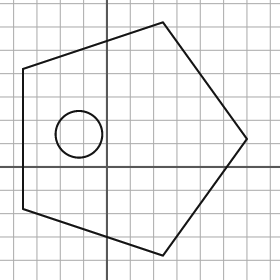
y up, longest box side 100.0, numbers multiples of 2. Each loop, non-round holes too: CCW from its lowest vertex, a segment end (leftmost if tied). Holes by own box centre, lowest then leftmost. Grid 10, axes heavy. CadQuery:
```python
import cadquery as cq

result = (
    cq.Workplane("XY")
    .moveTo(24.0, -38.0)
    .lineTo(60.0, 12.0)
    .lineTo(24.0, 62.0)
    .lineTo(-36.0, 42.0)
    .lineTo(-36.0, -18.0)
    .close()
    .moveTo(-12.0, 14.0)
    .circle(10.0)
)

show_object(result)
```